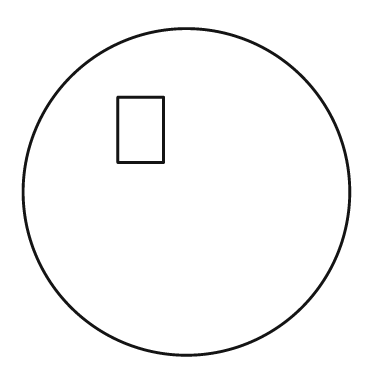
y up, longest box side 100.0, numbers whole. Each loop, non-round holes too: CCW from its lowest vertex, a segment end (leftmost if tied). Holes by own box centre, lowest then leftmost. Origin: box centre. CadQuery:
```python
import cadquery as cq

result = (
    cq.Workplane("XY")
    .moveTo(0.0, 0.0)
    .circle(50.0)
    .moveTo(-21.0, 9.0)
    .lineTo(-7.0, 9.0)
    .lineTo(-7.0, 29.0)
    .lineTo(-21.0, 29.0)
    .close()
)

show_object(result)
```